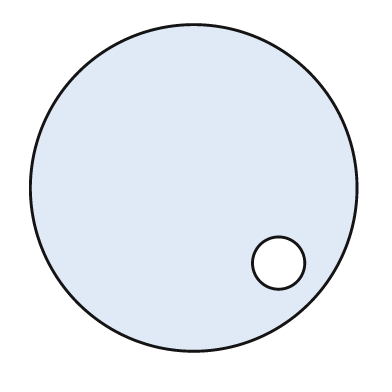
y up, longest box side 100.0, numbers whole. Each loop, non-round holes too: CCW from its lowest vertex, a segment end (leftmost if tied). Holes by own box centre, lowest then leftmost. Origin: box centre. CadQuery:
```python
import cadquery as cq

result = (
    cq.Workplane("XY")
    .moveTo(0.0, 0.0)
    .circle(50.0)
    .moveTo(26.0, -23.0)
    .circle(8.0)
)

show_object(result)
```